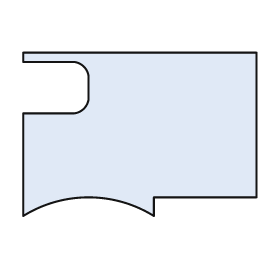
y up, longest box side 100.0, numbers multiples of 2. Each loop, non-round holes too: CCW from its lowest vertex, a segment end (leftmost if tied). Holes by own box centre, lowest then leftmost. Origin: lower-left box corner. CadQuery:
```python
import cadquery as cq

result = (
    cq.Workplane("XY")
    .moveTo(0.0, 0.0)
    .threePointArc((28.0, 8.0), (56.0, 0.0))
    .lineTo(56.0, 8.0)
    .lineTo(100.0, 8.0)
    .lineTo(100.0, 70.0)
    .lineTo(0.0, 70.0)
    .lineTo(0.0, 66.0)
    .lineTo(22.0, 66.0)
    .threePointArc((26.0, 64.0), (28.0, 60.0))
    .lineTo(28.0, 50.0)
    .threePointArc((26.0, 46.0), (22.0, 44.0))
    .lineTo(0.0, 44.0)
    .close()
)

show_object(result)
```